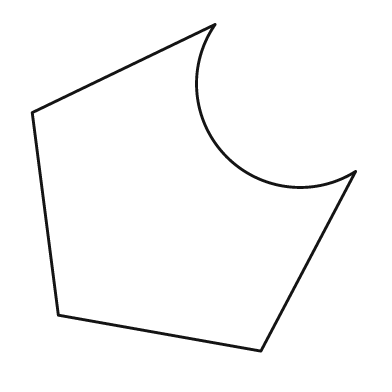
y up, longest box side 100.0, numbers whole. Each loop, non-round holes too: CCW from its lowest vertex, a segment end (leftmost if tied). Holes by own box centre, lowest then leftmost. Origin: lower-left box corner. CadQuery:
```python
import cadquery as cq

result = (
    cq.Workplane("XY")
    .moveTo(70.0, 0.0)
    .lineTo(99.0, 55.0)
    .threePointArc((59.0, 60.0), (56.0, 100.0))
    .lineTo(0.0, 73.0)
    .lineTo(8.0, 11.0)
    .close()
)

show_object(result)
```